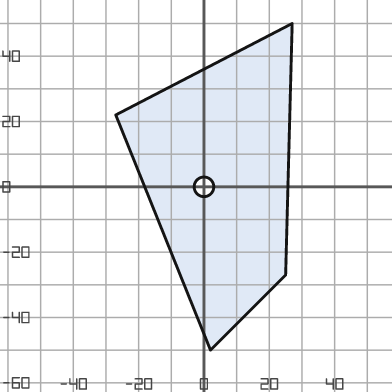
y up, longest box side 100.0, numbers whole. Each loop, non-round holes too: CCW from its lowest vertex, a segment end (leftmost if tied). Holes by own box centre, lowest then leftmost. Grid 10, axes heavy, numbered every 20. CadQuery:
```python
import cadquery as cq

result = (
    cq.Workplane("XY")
    .moveTo(2.0, -50.0)
    .lineTo(25.0, -27.0)
    .lineTo(27.0, 50.0)
    .lineTo(-27.0, 22.0)
    .close()
    .moveTo(0.0, 0.0)
    .circle(3.0)
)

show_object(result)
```